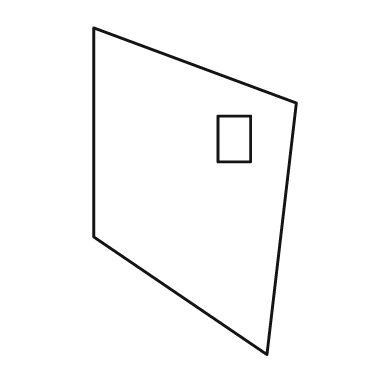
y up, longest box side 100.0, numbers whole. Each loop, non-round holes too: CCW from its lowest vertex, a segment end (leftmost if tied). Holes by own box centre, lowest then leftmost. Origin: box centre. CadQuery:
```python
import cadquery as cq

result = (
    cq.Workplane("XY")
    .moveTo(22.0, -50.0)
    .lineTo(31.0, 27.0)
    .lineTo(-31.0, 50.0)
    .lineTo(-31.0, -14.0)
    .close()
    .moveTo(7.0, 9.0)
    .lineTo(17.0, 9.0)
    .lineTo(17.0, 23.0)
    .lineTo(7.0, 23.0)
    .close()
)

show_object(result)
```